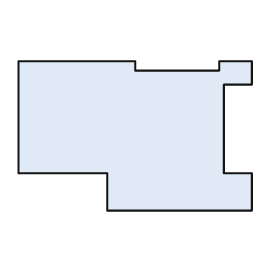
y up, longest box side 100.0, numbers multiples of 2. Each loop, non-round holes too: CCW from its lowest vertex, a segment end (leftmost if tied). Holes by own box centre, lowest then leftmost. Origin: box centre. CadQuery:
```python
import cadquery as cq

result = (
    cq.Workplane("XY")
    .moveTo(-12.0, -32.0)
    .lineTo(50.0, -32.0)
    .lineTo(50.0, -16.0)
    .lineTo(38.0, -16.0)
    .lineTo(38.0, 22.0)
    .lineTo(50.0, 22.0)
    .lineTo(50.0, 32.0)
    .lineTo(36.0, 32.0)
    .lineTo(36.0, 28.0)
    .lineTo(0.0, 28.0)
    .lineTo(0.0, 32.0)
    .lineTo(-50.0, 32.0)
    .lineTo(-50.0, -16.0)
    .lineTo(-12.0, -16.0)
    .close()
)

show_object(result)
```